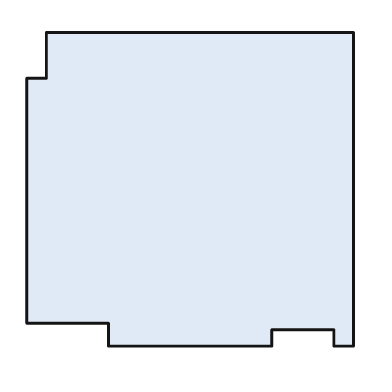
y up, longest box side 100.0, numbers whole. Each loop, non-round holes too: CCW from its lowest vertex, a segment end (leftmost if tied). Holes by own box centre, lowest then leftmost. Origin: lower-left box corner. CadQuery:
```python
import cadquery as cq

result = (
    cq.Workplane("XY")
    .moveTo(25.0, 0.0)
    .lineTo(75.0, 0.0)
    .lineTo(75.0, 5.0)
    .lineTo(94.0, 5.0)
    .lineTo(94.0, 0.0)
    .lineTo(100.0, 0.0)
    .lineTo(100.0, 96.0)
    .lineTo(6.0, 96.0)
    .lineTo(6.0, 82.0)
    .lineTo(0.0, 82.0)
    .lineTo(0.0, 7.0)
    .lineTo(25.0, 7.0)
    .close()
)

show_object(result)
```